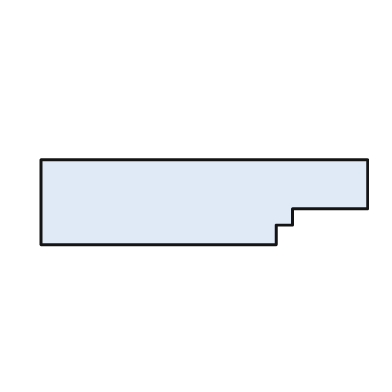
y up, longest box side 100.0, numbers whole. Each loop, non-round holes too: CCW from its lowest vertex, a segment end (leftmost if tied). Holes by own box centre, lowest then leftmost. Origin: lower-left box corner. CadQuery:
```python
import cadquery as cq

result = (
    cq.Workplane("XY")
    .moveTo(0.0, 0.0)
    .lineTo(72.0, 0.0)
    .lineTo(72.0, 6.0)
    .lineTo(77.0, 6.0)
    .lineTo(77.0, 11.0)
    .lineTo(100.0, 11.0)
    .lineTo(100.0, 26.0)
    .lineTo(0.0, 26.0)
    .close()
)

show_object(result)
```